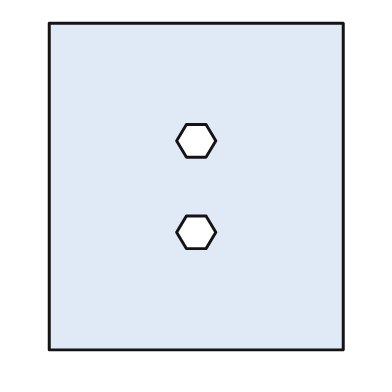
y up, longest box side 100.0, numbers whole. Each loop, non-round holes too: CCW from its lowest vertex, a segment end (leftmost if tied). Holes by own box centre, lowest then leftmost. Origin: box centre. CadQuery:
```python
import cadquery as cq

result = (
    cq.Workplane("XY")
    .moveTo(-45.0, -50.0)
    .lineTo(45.0, -50.0)
    .lineTo(45.0, 50.0)
    .lineTo(-45.0, 50.0)
    .close()
    .moveTo(-3.0, -19.0)
    .lineTo(3.0, -19.0)
    .lineTo(6.0, -14.0)
    .lineTo(3.0, -9.0)
    .lineTo(-3.0, -9.0)
    .lineTo(-6.0, -14.0)
    .close()
    .moveTo(-3.0, 9.0)
    .lineTo(3.0, 9.0)
    .lineTo(6.0, 14.0)
    .lineTo(3.0, 19.0)
    .lineTo(-3.0, 19.0)
    .lineTo(-6.0, 14.0)
    .close()
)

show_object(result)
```